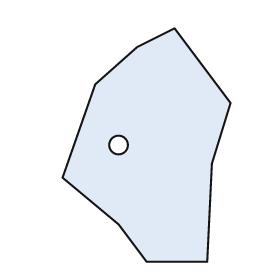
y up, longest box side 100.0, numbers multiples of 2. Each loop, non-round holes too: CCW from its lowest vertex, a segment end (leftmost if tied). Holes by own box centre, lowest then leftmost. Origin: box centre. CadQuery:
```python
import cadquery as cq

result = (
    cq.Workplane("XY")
    .moveTo(0.0, -50.0)
    .lineTo(26.0, -50.0)
    .lineTo(28.0, -8.0)
    .lineTo(36.0, 18.0)
    .lineTo(12.0, 50.0)
    .lineTo(-4.0, 42.0)
    .lineTo(-22.0, 26.0)
    .lineTo(-36.0, -14.0)
    .lineTo(-12.0, -34.0)
    .close()
    .moveTo(-12.0, 0.0)
    .circle(4.0)
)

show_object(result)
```